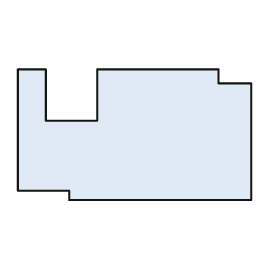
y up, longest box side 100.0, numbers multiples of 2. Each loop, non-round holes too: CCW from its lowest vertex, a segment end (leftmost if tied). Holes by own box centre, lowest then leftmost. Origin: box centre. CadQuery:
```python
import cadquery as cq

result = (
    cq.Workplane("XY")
    .moveTo(-28.0, -28.0)
    .lineTo(50.0, -28.0)
    .lineTo(50.0, 22.0)
    .lineTo(36.0, 22.0)
    .lineTo(36.0, 28.0)
    .lineTo(-16.0, 28.0)
    .lineTo(-16.0, 6.0)
    .lineTo(-38.0, 6.0)
    .lineTo(-38.0, 28.0)
    .lineTo(-50.0, 28.0)
    .lineTo(-50.0, -24.0)
    .lineTo(-28.0, -24.0)
    .close()
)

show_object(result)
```